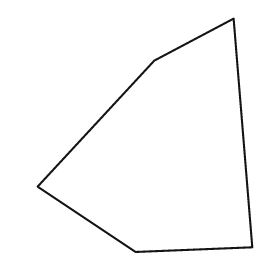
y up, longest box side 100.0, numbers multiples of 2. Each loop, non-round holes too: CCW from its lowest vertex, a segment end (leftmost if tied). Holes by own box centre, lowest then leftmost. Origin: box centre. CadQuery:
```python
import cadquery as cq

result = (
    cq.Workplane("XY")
    .moveTo(-4.0, -50.0)
    .lineTo(46.0, -48.0)
    .lineTo(38.0, 50.0)
    .lineTo(4.0, 32.0)
    .lineTo(-46.0, -22.0)
    .close()
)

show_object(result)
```